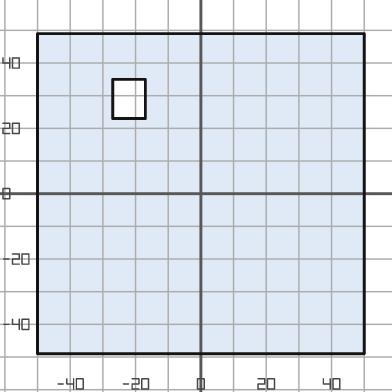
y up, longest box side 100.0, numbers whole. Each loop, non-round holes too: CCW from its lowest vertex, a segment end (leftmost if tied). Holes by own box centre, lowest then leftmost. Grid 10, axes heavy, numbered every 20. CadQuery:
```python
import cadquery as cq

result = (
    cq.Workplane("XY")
    .moveTo(-50.0, -49.0)
    .lineTo(50.0, -49.0)
    .lineTo(50.0, 49.0)
    .lineTo(-50.0, 49.0)
    .close()
    .moveTo(-27.0, 23.0)
    .lineTo(-17.0, 23.0)
    .lineTo(-17.0, 35.0)
    .lineTo(-27.0, 35.0)
    .close()
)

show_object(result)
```